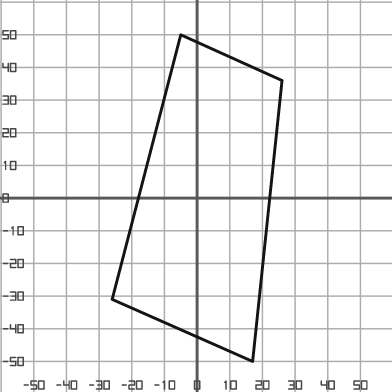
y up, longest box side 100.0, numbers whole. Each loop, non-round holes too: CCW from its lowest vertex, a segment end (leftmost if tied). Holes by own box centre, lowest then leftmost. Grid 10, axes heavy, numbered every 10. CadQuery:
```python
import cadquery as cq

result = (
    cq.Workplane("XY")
    .moveTo(17.0, -50.0)
    .lineTo(26.0, 36.0)
    .lineTo(-5.0, 50.0)
    .lineTo(-26.0, -31.0)
    .close()
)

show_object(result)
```